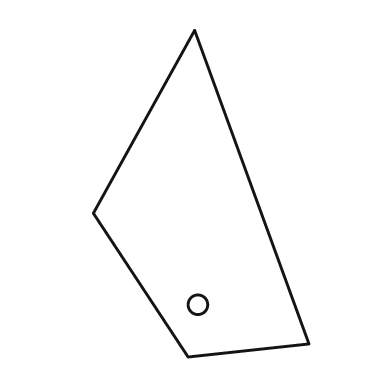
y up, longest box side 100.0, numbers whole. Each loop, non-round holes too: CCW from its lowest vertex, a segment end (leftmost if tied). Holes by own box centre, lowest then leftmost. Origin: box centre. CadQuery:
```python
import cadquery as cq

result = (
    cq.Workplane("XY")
    .moveTo(-4.0, -50.0)
    .lineTo(33.0, -46.0)
    .lineTo(-2.0, 50.0)
    .lineTo(-33.0, -6.0)
    .close()
    .moveTo(-1.0, -34.0)
    .circle(3.0)
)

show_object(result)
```